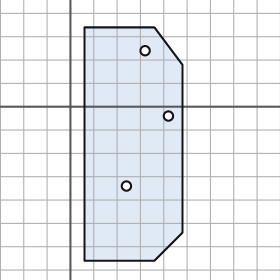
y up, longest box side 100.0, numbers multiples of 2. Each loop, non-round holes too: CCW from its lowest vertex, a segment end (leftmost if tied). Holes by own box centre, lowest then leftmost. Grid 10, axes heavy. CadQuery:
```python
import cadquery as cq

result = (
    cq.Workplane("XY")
    .moveTo(6.0, -66.0)
    .lineTo(36.0, -66.0)
    .lineTo(48.0, -54.0)
    .lineTo(48.0, 18.0)
    .lineTo(36.0, 34.0)
    .lineTo(6.0, 34.0)
    .close()
    .moveTo(24.0, -34.0)
    .circle(2.0)
    .moveTo(42.0, -4.0)
    .circle(2.0)
    .moveTo(32.0, 24.0)
    .circle(2.0)
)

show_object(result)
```